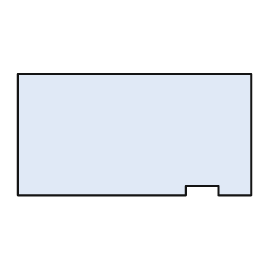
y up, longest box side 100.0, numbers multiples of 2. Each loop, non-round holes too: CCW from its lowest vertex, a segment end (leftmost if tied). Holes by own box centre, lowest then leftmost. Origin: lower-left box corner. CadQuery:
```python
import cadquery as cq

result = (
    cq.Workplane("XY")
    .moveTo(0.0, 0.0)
    .lineTo(72.0, 0.0)
    .lineTo(72.0, 4.0)
    .lineTo(86.0, 4.0)
    .lineTo(86.0, 0.0)
    .lineTo(100.0, 0.0)
    .lineTo(100.0, 52.0)
    .lineTo(0.0, 52.0)
    .close()
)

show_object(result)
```